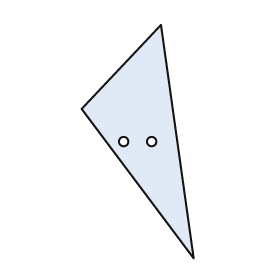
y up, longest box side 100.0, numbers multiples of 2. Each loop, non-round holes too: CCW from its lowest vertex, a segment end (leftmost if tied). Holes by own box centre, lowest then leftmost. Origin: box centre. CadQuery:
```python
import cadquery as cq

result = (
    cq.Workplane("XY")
    .moveTo(24.0, -50.0)
    .lineTo(10.0, 50.0)
    .lineTo(-24.0, 14.0)
    .close()
    .moveTo(-6.0, 0.0)
    .circle(2.0)
    .moveTo(6.0, 0.0)
    .circle(2.0)
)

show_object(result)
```